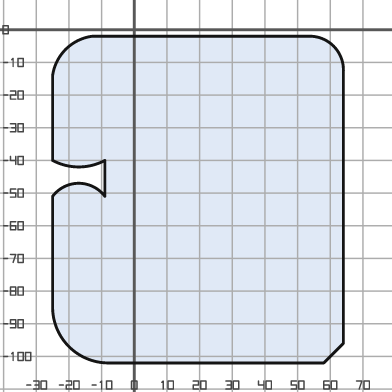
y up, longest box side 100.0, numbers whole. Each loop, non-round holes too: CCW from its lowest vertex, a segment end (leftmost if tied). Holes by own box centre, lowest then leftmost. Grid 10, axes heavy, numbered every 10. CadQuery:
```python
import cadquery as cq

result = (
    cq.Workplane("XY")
    .moveTo(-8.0, -102.0)
    .lineTo(58.0, -102.0)
    .lineTo(64.0, -96.0)
    .lineTo(64.0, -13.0)
    .threePointArc((61.0, -5.0), (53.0, -2.0))
    .lineTo(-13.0, -2.0)
    .threePointArc((-21.0, -6.0), (-25.0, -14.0))
    .lineTo(-25.0, -40.0)
    .threePointArc((-17.0, -42.0), (-9.0, -40.0))
    .lineTo(-9.0, -51.0)
    .threePointArc((-17.0, -47.0), (-25.0, -51.0))
    .lineTo(-25.0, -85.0)
    .threePointArc((-20.0, -97.0), (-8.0, -102.0))
    .close()
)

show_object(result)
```